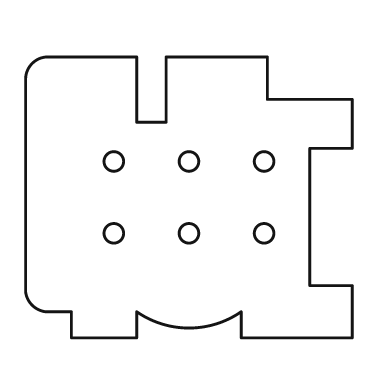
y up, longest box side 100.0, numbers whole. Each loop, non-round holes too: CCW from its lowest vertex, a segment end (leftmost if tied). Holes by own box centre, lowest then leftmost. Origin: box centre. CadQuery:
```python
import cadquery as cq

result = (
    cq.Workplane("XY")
    .moveTo(-36.0, -43.0)
    .lineTo(-16.0, -43.0)
    .lineTo(-16.0, -35.0)
    .threePointArc((0.0, -40.0), (16.0, -35.0))
    .lineTo(16.0, -43.0)
    .lineTo(50.0, -43.0)
    .lineTo(50.0, -27.0)
    .lineTo(37.0, -27.0)
    .lineTo(37.0, 15.0)
    .lineTo(50.0, 15.0)
    .lineTo(50.0, 30.0)
    .lineTo(24.0, 30.0)
    .lineTo(24.0, 43.0)
    .lineTo(-7.0, 43.0)
    .lineTo(-7.0, 23.0)
    .lineTo(-16.0, 23.0)
    .lineTo(-16.0, 43.0)
    .lineTo(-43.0, 43.0)
    .threePointArc((-48.0, 41.0), (-50.0, 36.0))
    .lineTo(-50.0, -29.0)
    .threePointArc((-48.0, -33.0), (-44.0, -35.0))
    .lineTo(-36.0, -35.0)
    .close()
    .moveTo(-23.0, -11.0)
    .circle(3.0)
    .moveTo(0.0, -11.0)
    .circle(3.0)
    .moveTo(23.0, -11.0)
    .circle(3.0)
    .moveTo(-23.0, 11.0)
    .circle(3.0)
    .moveTo(0.0, 11.0)
    .circle(3.0)
    .moveTo(23.0, 11.0)
    .circle(3.0)
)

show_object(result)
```